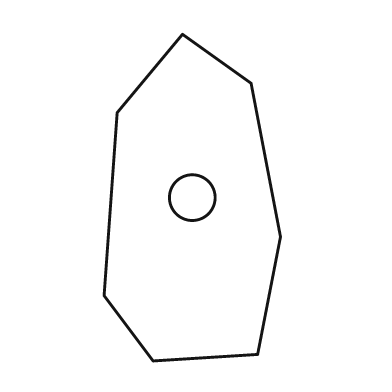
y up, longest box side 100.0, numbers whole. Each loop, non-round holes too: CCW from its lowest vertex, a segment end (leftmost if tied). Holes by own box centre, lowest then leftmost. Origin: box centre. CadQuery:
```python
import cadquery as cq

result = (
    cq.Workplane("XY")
    .moveTo(-12.0, -50.0)
    .lineTo(20.0, -48.0)
    .lineTo(27.0, -12.0)
    .lineTo(18.0, 35.0)
    .lineTo(-3.0, 50.0)
    .lineTo(-23.0, 26.0)
    .lineTo(-27.0, -30.0)
    .close()
    .moveTo(0.0, 0.0)
    .circle(7.0)
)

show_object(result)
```